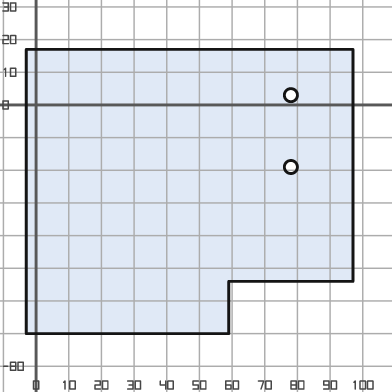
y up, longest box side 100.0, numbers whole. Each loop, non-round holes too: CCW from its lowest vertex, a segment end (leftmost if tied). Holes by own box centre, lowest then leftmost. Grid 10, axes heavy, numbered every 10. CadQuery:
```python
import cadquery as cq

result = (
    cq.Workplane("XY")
    .moveTo(-3.0, -70.0)
    .lineTo(59.0, -70.0)
    .lineTo(59.0, -54.0)
    .lineTo(97.0, -54.0)
    .lineTo(97.0, 17.0)
    .lineTo(-3.0, 17.0)
    .close()
    .moveTo(78.0, -19.0)
    .circle(2.0)
    .moveTo(78.0, 3.0)
    .circle(2.0)
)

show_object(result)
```